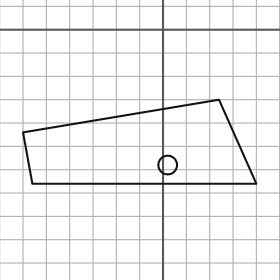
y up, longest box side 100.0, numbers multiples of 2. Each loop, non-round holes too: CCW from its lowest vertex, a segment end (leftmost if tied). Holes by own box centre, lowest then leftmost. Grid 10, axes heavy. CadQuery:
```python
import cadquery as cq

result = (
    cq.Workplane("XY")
    .moveTo(-56.0, -66.0)
    .lineTo(40.0, -66.0)
    .lineTo(24.0, -30.0)
    .lineTo(-60.0, -44.0)
    .close()
    .moveTo(2.0, -58.0)
    .circle(4.0)
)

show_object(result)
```